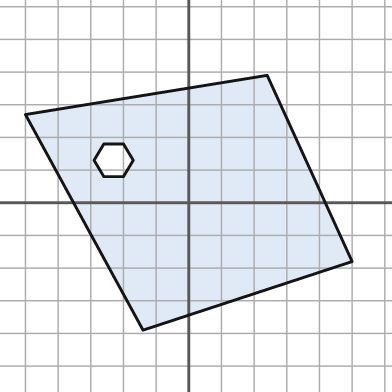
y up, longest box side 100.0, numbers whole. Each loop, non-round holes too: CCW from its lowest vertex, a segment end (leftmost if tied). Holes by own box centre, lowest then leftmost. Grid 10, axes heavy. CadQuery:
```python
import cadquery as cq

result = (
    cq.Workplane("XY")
    .moveTo(-14.0, -39.0)
    .lineTo(50.0, -18.0)
    .lineTo(24.0, 39.0)
    .lineTo(-50.0, 27.0)
    .close()
    .moveTo(-26.0, 8.0)
    .lineTo(-20.0, 8.0)
    .lineTo(-17.0, 13.0)
    .lineTo(-20.0, 18.0)
    .lineTo(-26.0, 18.0)
    .lineTo(-29.0, 13.0)
    .close()
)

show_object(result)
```